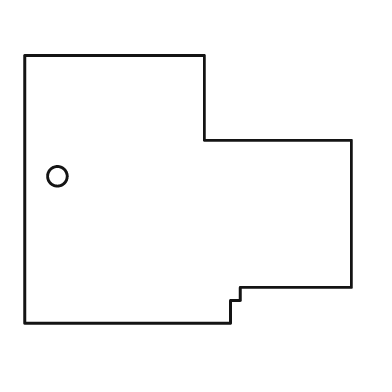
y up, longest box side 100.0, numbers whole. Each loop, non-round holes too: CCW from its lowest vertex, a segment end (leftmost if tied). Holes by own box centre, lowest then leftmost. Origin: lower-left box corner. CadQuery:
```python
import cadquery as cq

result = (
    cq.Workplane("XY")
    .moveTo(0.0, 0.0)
    .lineTo(63.0, 0.0)
    .lineTo(63.0, 7.0)
    .lineTo(66.0, 7.0)
    .lineTo(66.0, 11.0)
    .lineTo(100.0, 11.0)
    .lineTo(100.0, 56.0)
    .lineTo(55.0, 56.0)
    .lineTo(55.0, 82.0)
    .lineTo(0.0, 82.0)
    .close()
    .moveTo(10.0, 45.0)
    .circle(3.0)
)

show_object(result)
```